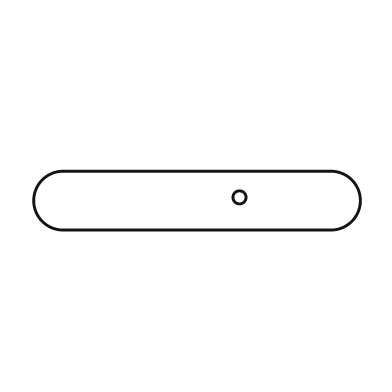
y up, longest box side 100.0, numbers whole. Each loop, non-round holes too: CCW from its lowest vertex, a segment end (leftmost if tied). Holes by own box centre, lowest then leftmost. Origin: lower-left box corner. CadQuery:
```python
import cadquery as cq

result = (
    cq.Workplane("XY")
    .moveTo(9.0, 0.0)
    .lineTo(91.0, 0.0)
    .threePointArc((100.0, 9.0), (91.0, 18.0))
    .lineTo(9.0, 18.0)
    .threePointArc((0.0, 9.0), (9.0, 0.0))
    .close()
    .moveTo(63.0, 10.0)
    .circle(2.0)
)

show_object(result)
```